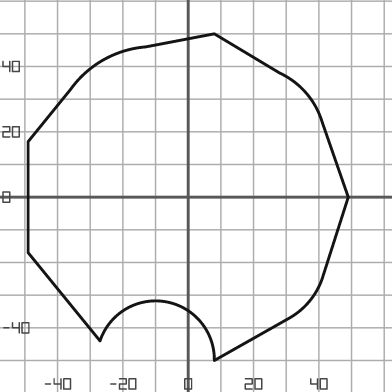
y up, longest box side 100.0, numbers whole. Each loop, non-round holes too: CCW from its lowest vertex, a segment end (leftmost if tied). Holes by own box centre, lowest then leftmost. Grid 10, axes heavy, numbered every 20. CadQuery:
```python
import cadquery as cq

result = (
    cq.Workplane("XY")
    .moveTo(8.0, -50.0)
    .lineTo(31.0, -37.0)
    .threePointArc((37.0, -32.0), (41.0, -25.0))
    .lineTo(49.0, 0.0)
    .lineTo(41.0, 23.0)
    .threePointArc((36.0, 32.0), (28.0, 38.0))
    .lineTo(8.0, 50.0)
    .lineTo(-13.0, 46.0)
    .threePointArc((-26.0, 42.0), (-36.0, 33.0))
    .lineTo(-49.0, 17.0)
    .lineTo(-49.0, -17.0)
    .lineTo(-27.0, -44.0)
    .threePointArc((-7.0, -32.0), (8.0, -50.0))
    .close()
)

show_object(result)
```